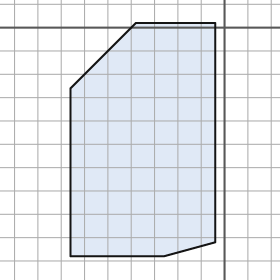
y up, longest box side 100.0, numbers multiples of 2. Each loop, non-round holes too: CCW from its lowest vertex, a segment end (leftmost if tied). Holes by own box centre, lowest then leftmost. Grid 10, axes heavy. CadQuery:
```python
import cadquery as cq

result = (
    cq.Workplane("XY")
    .moveTo(-66.0, -98.0)
    .lineTo(-26.0, -98.0)
    .lineTo(-4.0, -92.0)
    .lineTo(-4.0, 2.0)
    .lineTo(-38.0, 2.0)
    .lineTo(-66.0, -26.0)
    .close()
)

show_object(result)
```